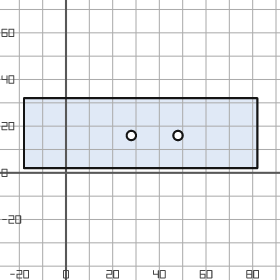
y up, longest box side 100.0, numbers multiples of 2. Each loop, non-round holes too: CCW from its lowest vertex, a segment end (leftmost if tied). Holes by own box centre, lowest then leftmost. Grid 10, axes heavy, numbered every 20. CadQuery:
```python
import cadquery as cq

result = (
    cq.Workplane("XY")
    .moveTo(-18.0, 2.0)
    .lineTo(82.0, 2.0)
    .lineTo(82.0, 32.0)
    .lineTo(-18.0, 32.0)
    .close()
    .moveTo(28.0, 16.0)
    .circle(2.0)
    .moveTo(48.0, 16.0)
    .circle(2.0)
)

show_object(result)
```